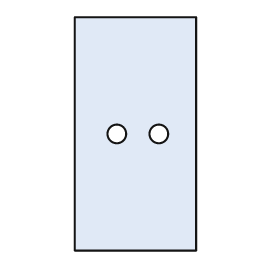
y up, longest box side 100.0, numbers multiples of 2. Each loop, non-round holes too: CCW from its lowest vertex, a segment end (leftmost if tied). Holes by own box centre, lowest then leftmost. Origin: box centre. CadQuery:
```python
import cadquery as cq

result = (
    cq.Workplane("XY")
    .moveTo(-26.0, -50.0)
    .lineTo(26.0, -50.0)
    .lineTo(26.0, 50.0)
    .lineTo(-26.0, 50.0)
    .close()
    .moveTo(-8.0, 0.0)
    .circle(4.0)
    .moveTo(10.0, 0.0)
    .circle(4.0)
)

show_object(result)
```